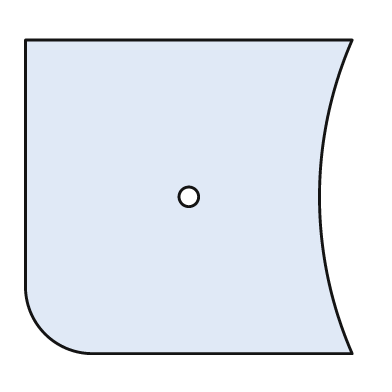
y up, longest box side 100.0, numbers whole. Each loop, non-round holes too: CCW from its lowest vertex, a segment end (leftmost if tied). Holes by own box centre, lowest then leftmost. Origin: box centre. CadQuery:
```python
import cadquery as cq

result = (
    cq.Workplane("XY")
    .moveTo(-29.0, -48.0)
    .lineTo(50.0, -48.0)
    .threePointArc((40.0, 0.0), (50.0, 48.0))
    .lineTo(-50.0, 48.0)
    .lineTo(-50.0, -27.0)
    .threePointArc((-44.0, -42.0), (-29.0, -48.0))
    .close()
    .moveTo(0.0, 0.0)
    .circle(3.0)
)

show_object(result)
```